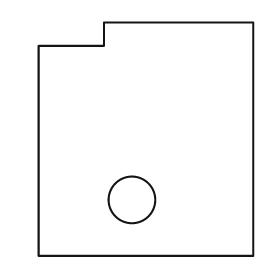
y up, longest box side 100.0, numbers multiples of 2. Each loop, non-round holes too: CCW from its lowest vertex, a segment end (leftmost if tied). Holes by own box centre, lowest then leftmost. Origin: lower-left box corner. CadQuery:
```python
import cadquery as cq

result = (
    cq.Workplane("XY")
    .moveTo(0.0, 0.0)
    .lineTo(92.0, 0.0)
    .lineTo(92.0, 100.0)
    .lineTo(28.0, 100.0)
    .lineTo(28.0, 90.0)
    .lineTo(0.0, 90.0)
    .close()
    .moveTo(40.0, 24.0)
    .circle(10.0)
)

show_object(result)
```